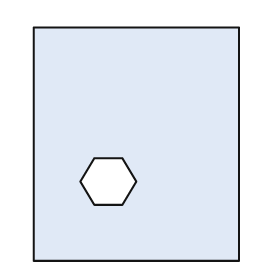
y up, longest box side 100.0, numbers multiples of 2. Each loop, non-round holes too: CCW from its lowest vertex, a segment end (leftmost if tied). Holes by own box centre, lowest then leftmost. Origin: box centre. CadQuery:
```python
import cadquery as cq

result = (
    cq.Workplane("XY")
    .moveTo(-44.0, -50.0)
    .lineTo(44.0, -50.0)
    .lineTo(44.0, 50.0)
    .lineTo(-44.0, 50.0)
    .close()
    .moveTo(-18.0, -26.0)
    .lineTo(-6.0, -26.0)
    .lineTo(0.0, -16.0)
    .lineTo(-6.0, -6.0)
    .lineTo(-18.0, -6.0)
    .lineTo(-24.0, -16.0)
    .close()
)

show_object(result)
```